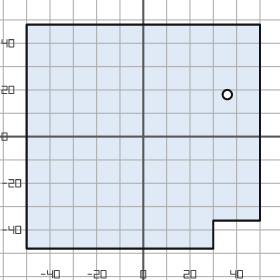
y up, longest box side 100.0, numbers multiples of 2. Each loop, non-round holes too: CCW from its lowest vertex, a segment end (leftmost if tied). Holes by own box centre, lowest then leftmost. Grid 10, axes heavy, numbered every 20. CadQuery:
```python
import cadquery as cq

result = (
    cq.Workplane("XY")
    .moveTo(-50.0, -48.0)
    .lineTo(30.0, -48.0)
    .lineTo(30.0, -36.0)
    .lineTo(50.0, -36.0)
    .lineTo(50.0, 48.0)
    .lineTo(-50.0, 48.0)
    .close()
    .moveTo(36.0, 18.0)
    .circle(2.0)
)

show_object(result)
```